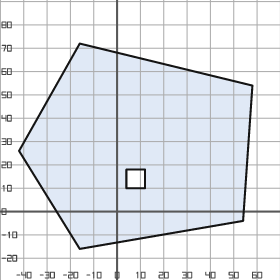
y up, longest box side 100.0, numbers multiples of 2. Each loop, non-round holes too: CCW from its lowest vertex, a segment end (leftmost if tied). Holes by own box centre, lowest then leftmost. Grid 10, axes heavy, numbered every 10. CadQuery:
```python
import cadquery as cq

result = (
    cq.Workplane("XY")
    .moveTo(-16.0, -16.0)
    .lineTo(54.0, -4.0)
    .lineTo(58.0, 54.0)
    .lineTo(-16.0, 72.0)
    .lineTo(-42.0, 26.0)
    .close()
    .moveTo(4.0, 10.0)
    .lineTo(12.0, 10.0)
    .lineTo(12.0, 18.0)
    .lineTo(4.0, 18.0)
    .close()
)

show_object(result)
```